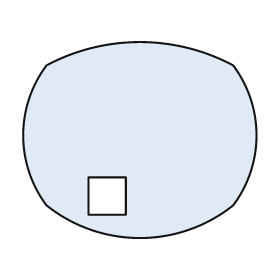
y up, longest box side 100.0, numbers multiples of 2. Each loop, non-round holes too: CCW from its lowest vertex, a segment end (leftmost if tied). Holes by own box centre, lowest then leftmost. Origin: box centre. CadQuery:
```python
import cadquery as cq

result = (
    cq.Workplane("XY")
    .moveTo(-40.0, -28.0)
    .threePointArc((0.0, -42.0), (40.0, -28.0))
    .threePointArc((50.0, 2.0), (40.0, 32.0))
    .threePointArc((0.0, 42.0), (-40.0, 32.0))
    .threePointArc((-50.0, 2.0), (-40.0, -28.0))
    .close()
    .moveTo(-22.0, -32.0)
    .lineTo(-6.0, -32.0)
    .lineTo(-6.0, -16.0)
    .lineTo(-22.0, -16.0)
    .close()
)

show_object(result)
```